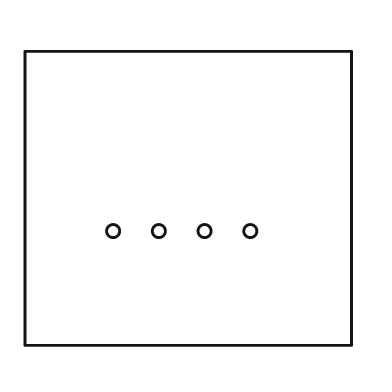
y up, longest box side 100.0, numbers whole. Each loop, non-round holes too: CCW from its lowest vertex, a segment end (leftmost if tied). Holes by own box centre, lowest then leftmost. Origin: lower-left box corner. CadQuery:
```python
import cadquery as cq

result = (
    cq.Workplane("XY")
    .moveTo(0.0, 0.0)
    .lineTo(100.0, 0.0)
    .lineTo(100.0, 90.0)
    .lineTo(0.0, 90.0)
    .close()
    .moveTo(27.0, 35.0)
    .circle(2.0)
    .moveTo(41.0, 35.0)
    .circle(2.0)
    .moveTo(55.0, 35.0)
    .circle(2.0)
    .moveTo(69.0, 35.0)
    .circle(2.0)
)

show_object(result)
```